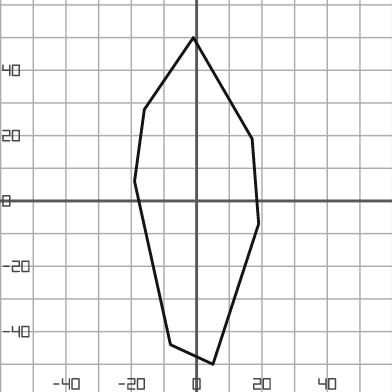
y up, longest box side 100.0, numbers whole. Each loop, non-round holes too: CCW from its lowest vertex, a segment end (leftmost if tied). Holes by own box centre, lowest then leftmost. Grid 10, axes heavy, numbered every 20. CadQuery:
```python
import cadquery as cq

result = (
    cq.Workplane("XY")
    .moveTo(5.0, -50.0)
    .lineTo(19.0, -7.0)
    .lineTo(17.0, 19.0)
    .lineTo(-1.0, 50.0)
    .lineTo(-16.0, 28.0)
    .lineTo(-19.0, 6.0)
    .lineTo(-8.0, -44.0)
    .close()
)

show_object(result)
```